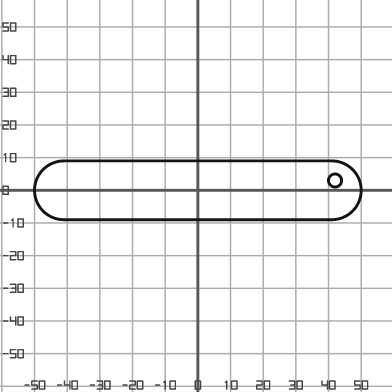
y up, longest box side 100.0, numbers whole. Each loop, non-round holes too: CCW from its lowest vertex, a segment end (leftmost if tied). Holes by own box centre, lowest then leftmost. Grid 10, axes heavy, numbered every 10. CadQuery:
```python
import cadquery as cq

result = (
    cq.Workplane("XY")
    .moveTo(-41.0, -9.0)
    .lineTo(41.0, -9.0)
    .threePointArc((50.0, 0.0), (41.0, 9.0))
    .lineTo(-41.0, 9.0)
    .threePointArc((-50.0, 0.0), (-41.0, -9.0))
    .close()
    .moveTo(42.0, 3.0)
    .circle(2.0)
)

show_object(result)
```